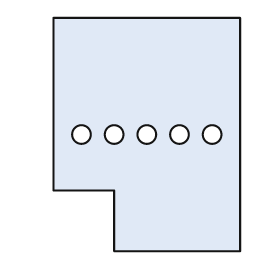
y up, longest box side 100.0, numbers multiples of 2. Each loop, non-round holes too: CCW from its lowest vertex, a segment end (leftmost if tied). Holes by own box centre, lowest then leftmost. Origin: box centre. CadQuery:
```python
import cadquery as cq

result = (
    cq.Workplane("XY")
    .moveTo(-14.0, -50.0)
    .lineTo(40.0, -50.0)
    .lineTo(40.0, 50.0)
    .lineTo(-40.0, 50.0)
    .lineTo(-40.0, -24.0)
    .lineTo(-14.0, -24.0)
    .close()
    .moveTo(-28.0, 0.0)
    .circle(4.0)
    .moveTo(-14.0, 0.0)
    .circle(4.0)
    .moveTo(0.0, 0.0)
    .circle(4.0)
    .moveTo(14.0, 0.0)
    .circle(4.0)
    .moveTo(28.0, 0.0)
    .circle(4.0)
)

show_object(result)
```